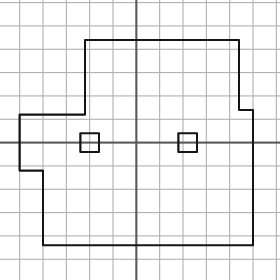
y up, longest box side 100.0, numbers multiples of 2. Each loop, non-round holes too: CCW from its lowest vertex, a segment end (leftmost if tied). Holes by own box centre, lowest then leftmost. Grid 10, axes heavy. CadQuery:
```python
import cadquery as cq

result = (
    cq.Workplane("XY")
    .moveTo(-40.0, -44.0)
    .lineTo(50.0, -44.0)
    .lineTo(50.0, 14.0)
    .lineTo(44.0, 14.0)
    .lineTo(44.0, 44.0)
    .lineTo(-22.0, 44.0)
    .lineTo(-22.0, 12.0)
    .lineTo(-50.0, 12.0)
    .lineTo(-50.0, -12.0)
    .lineTo(-40.0, -12.0)
    .close()
    .moveTo(-24.0, -4.0)
    .lineTo(-16.0, -4.0)
    .lineTo(-16.0, 4.0)
    .lineTo(-24.0, 4.0)
    .close()
    .moveTo(18.0, -4.0)
    .lineTo(26.0, -4.0)
    .lineTo(26.0, 4.0)
    .lineTo(18.0, 4.0)
    .close()
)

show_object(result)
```